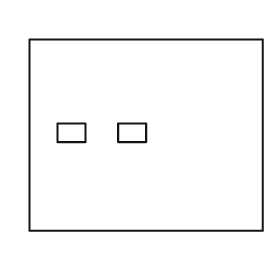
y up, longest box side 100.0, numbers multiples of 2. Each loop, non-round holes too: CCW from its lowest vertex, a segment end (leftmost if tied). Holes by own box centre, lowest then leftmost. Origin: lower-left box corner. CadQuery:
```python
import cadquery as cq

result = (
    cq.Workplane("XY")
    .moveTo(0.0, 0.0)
    .lineTo(100.0, 0.0)
    .lineTo(100.0, 82.0)
    .lineTo(0.0, 82.0)
    .close()
    .moveTo(12.0, 38.0)
    .lineTo(24.0, 38.0)
    .lineTo(24.0, 46.0)
    .lineTo(12.0, 46.0)
    .close()
    .moveTo(38.0, 38.0)
    .lineTo(50.0, 38.0)
    .lineTo(50.0, 46.0)
    .lineTo(38.0, 46.0)
    .close()
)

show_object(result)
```